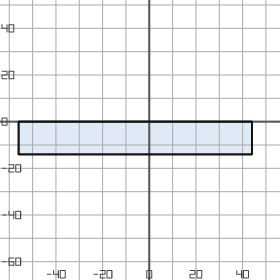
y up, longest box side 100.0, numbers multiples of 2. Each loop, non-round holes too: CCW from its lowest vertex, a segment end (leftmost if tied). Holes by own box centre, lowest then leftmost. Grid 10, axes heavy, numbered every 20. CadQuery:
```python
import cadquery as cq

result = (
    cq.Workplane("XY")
    .moveTo(-56.0, -14.0)
    .lineTo(44.0, -14.0)
    .lineTo(44.0, 0.0)
    .lineTo(-56.0, 0.0)
    .close()
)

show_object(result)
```